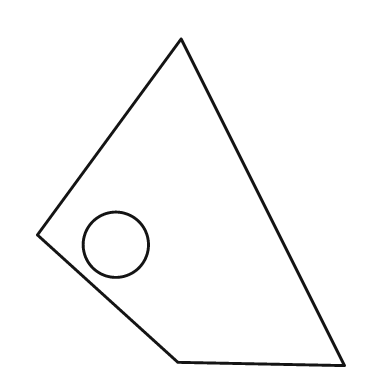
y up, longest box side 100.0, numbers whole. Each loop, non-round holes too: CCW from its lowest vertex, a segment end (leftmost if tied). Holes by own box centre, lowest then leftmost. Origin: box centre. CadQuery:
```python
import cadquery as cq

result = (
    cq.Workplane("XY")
    .moveTo(47.0, -50.0)
    .lineTo(-3.0, 50.0)
    .lineTo(-47.0, -10.0)
    .lineTo(-4.0, -49.0)
    .close()
    .moveTo(-23.0, -13.0)
    .circle(10.0)
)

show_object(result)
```